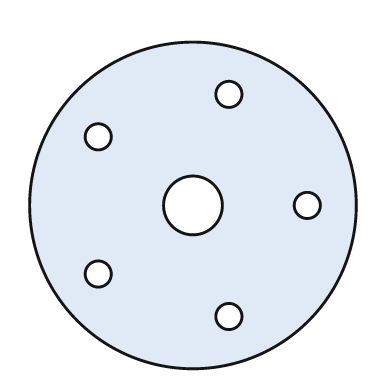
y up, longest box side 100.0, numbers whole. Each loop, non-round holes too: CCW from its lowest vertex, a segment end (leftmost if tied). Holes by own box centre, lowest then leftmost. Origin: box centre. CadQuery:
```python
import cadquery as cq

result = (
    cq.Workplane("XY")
    .moveTo(0.0, 0.0)
    .circle(50.0)
    .moveTo(11.0, -34.0)
    .circle(4.0)
    .moveTo(-29.0, -21.0)
    .circle(4.0)
    .moveTo(0.0, 0.0)
    .circle(9.0)
    .moveTo(35.0, 0.0)
    .circle(4.0)
    .moveTo(-29.0, 21.0)
    .circle(4.0)
    .moveTo(11.0, 34.0)
    .circle(4.0)
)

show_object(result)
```